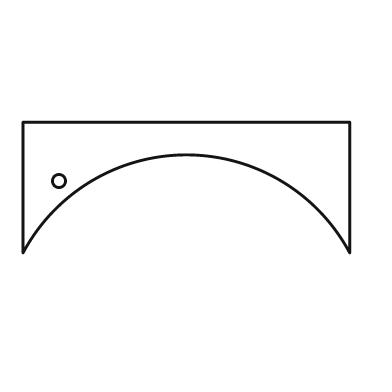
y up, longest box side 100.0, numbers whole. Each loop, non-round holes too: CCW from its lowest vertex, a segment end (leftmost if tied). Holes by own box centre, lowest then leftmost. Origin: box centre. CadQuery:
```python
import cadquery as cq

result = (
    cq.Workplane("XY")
    .moveTo(-50.0, -20.0)
    .threePointArc((0.0, 10.0), (50.0, -20.0))
    .lineTo(50.0, 20.0)
    .lineTo(-50.0, 20.0)
    .close()
    .moveTo(-39.0, 2.0)
    .circle(2.0)
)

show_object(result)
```